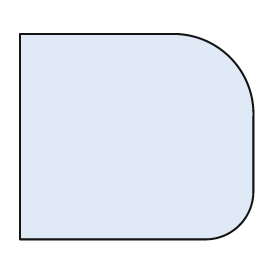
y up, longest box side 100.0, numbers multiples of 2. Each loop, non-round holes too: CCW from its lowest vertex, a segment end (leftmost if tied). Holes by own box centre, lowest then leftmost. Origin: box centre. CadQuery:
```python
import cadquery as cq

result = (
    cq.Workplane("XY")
    .moveTo(-50.0, -44.0)
    .lineTo(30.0, -44.0)
    .threePointArc((44.0, -38.0), (50.0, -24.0))
    .lineTo(50.0, 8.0)
    .threePointArc((40.0, 34.0), (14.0, 44.0))
    .lineTo(-50.0, 44.0)
    .close()
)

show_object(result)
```